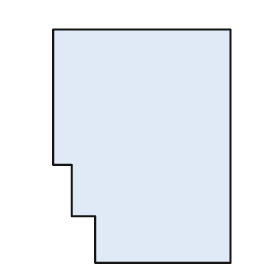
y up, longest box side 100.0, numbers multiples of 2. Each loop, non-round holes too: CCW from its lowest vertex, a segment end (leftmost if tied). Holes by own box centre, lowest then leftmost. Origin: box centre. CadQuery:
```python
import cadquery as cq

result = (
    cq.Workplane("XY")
    .moveTo(-20.0, -50.0)
    .lineTo(38.0, -50.0)
    .lineTo(38.0, 50.0)
    .lineTo(-38.0, 50.0)
    .lineTo(-38.0, -8.0)
    .lineTo(-30.0, -8.0)
    .lineTo(-30.0, -30.0)
    .lineTo(-20.0, -30.0)
    .close()
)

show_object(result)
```